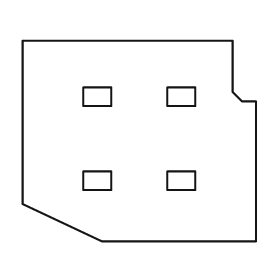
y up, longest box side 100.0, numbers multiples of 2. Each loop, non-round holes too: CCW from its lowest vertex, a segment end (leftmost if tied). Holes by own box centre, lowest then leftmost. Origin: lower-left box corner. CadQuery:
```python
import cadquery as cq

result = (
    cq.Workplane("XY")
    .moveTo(34.0, 0.0)
    .lineTo(100.0, 0.0)
    .lineTo(100.0, 60.0)
    .lineTo(94.0, 60.0)
    .lineTo(90.0, 64.0)
    .lineTo(90.0, 86.0)
    .lineTo(0.0, 86.0)
    .lineTo(0.0, 16.0)
    .close()
    .moveTo(26.0, 22.0)
    .lineTo(38.0, 22.0)
    .lineTo(38.0, 30.0)
    .lineTo(26.0, 30.0)
    .close()
    .moveTo(62.0, 22.0)
    .lineTo(74.0, 22.0)
    .lineTo(74.0, 30.0)
    .lineTo(62.0, 30.0)
    .close()
    .moveTo(26.0, 58.0)
    .lineTo(38.0, 58.0)
    .lineTo(38.0, 66.0)
    .lineTo(26.0, 66.0)
    .close()
    .moveTo(62.0, 58.0)
    .lineTo(74.0, 58.0)
    .lineTo(74.0, 66.0)
    .lineTo(62.0, 66.0)
    .close()
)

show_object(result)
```